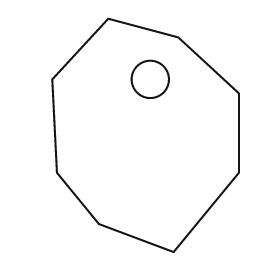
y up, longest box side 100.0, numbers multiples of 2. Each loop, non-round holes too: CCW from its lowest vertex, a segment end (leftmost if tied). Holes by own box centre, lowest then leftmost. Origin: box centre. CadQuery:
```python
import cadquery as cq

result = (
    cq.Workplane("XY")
    .moveTo(12.0, -50.0)
    .lineTo(40.0, -16.0)
    .lineTo(40.0, 18.0)
    .lineTo(14.0, 42.0)
    .lineTo(-16.0, 50.0)
    .lineTo(-40.0, 24.0)
    .lineTo(-38.0, -16.0)
    .lineTo(-20.0, -38.0)
    .close()
    .moveTo(2.0, 24.0)
    .circle(8.0)
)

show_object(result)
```